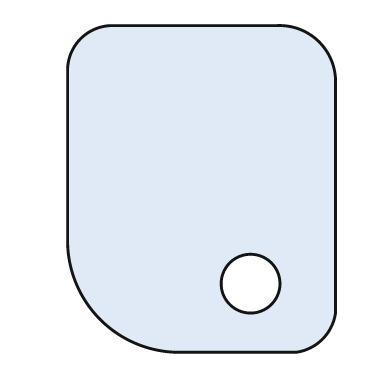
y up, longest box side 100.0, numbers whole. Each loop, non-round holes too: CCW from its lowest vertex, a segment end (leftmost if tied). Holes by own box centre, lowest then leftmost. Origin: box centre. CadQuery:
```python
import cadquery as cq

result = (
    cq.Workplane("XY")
    .moveTo(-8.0, -50.0)
    .lineTo(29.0, -50.0)
    .threePointArc((37.0, -46.0), (41.0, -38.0))
    .lineTo(41.0, 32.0)
    .threePointArc((36.0, 45.0), (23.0, 50.0))
    .lineTo(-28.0, 50.0)
    .threePointArc((-37.0, 46.0), (-41.0, 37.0))
    .lineTo(-41.0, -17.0)
    .threePointArc((-31.0, -40.0), (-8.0, -50.0))
    .close()
    .moveTo(15.0, -29.0)
    .circle(9.0)
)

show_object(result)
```